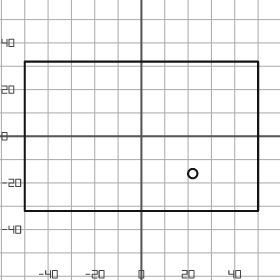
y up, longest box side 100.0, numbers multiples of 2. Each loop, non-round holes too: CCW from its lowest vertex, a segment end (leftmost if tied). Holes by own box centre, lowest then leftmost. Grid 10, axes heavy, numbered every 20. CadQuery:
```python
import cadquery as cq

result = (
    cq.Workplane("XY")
    .moveTo(-50.0, -32.0)
    .lineTo(50.0, -32.0)
    .lineTo(50.0, 32.0)
    .lineTo(-50.0, 32.0)
    .close()
    .moveTo(22.0, -16.0)
    .circle(2.0)
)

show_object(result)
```